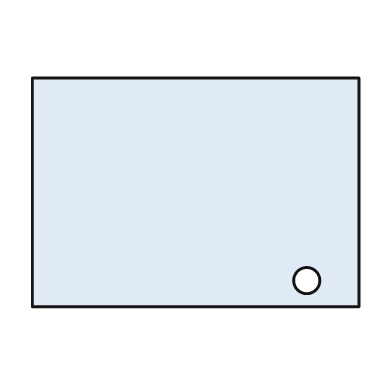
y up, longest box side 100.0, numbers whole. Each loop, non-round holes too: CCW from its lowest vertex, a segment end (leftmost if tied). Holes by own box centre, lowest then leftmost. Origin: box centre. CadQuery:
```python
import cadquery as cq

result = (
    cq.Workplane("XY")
    .moveTo(-50.0, -35.0)
    .lineTo(50.0, -35.0)
    .lineTo(50.0, 35.0)
    .lineTo(-50.0, 35.0)
    .close()
    .moveTo(34.0, -27.0)
    .circle(4.0)
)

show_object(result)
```